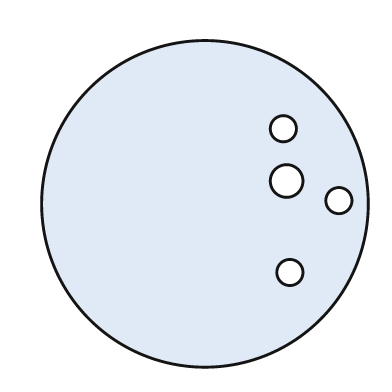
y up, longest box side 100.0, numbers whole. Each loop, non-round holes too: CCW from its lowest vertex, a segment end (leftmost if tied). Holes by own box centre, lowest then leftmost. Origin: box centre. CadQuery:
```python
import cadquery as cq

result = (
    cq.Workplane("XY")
    .moveTo(0.0, 0.0)
    .circle(50.0)
    .moveTo(26.0, -21.0)
    .circle(4.0)
    .moveTo(41.0, 1.0)
    .circle(4.0)
    .moveTo(25.0, 7.0)
    .circle(5.0)
    .moveTo(24.0, 23.0)
    .circle(4.0)
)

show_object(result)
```